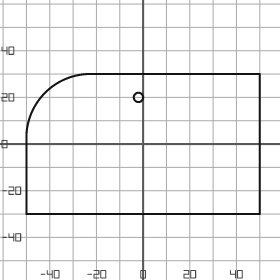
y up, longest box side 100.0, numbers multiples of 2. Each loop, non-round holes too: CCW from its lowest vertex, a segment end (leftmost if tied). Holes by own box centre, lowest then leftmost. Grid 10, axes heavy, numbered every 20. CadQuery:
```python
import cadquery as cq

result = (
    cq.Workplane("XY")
    .moveTo(-50.0, -30.0)
    .lineTo(50.0, -30.0)
    .lineTo(50.0, 30.0)
    .lineTo(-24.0, 30.0)
    .threePointArc((-42.0, 22.0), (-50.0, 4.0))
    .close()
    .moveTo(-2.0, 20.0)
    .circle(2.0)
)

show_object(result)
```